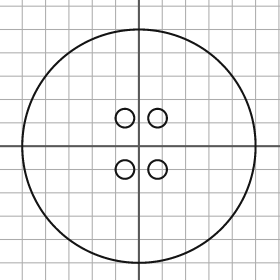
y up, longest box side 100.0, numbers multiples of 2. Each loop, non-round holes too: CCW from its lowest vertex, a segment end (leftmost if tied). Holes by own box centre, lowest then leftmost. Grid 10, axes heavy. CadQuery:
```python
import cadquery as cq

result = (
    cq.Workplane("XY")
    .moveTo(0.0, 0.0)
    .circle(50.0)
    .moveTo(-6.0, -10.0)
    .circle(4.0)
    .moveTo(8.0, -10.0)
    .circle(4.0)
    .moveTo(-6.0, 12.0)
    .circle(4.0)
    .moveTo(8.0, 12.0)
    .circle(4.0)
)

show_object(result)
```